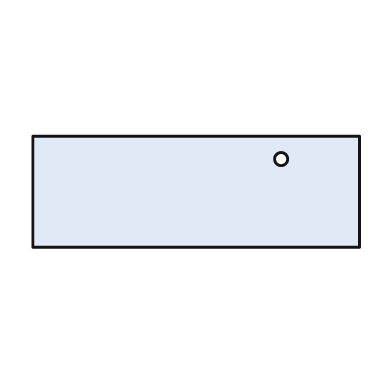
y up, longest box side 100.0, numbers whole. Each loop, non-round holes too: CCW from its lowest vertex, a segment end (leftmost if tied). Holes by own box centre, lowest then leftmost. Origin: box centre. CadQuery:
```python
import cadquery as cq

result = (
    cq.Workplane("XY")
    .moveTo(-50.0, -17.0)
    .lineTo(50.0, -17.0)
    .lineTo(50.0, 17.0)
    .lineTo(-50.0, 17.0)
    .close()
    .moveTo(26.0, 10.0)
    .circle(2.0)
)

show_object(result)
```